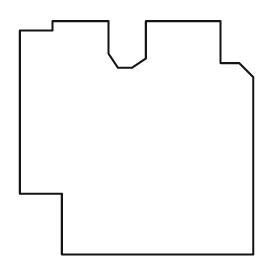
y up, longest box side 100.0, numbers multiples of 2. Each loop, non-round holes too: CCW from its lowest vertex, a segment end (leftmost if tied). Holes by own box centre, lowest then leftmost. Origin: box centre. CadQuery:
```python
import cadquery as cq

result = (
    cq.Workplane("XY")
    .moveTo(-32.0, -50.0)
    .lineTo(50.0, -50.0)
    .lineTo(50.0, 26.0)
    .lineTo(44.0, 32.0)
    .lineTo(36.0, 32.0)
    .lineTo(36.0, 50.0)
    .lineTo(4.0, 50.0)
    .lineTo(4.0, 34.0)
    .lineTo(-2.0, 30.0)
    .lineTo(-8.0, 30.0)
    .lineTo(-12.0, 36.0)
    .lineTo(-12.0, 50.0)
    .lineTo(-36.0, 50.0)
    .lineTo(-36.0, 46.0)
    .lineTo(-50.0, 46.0)
    .lineTo(-50.0, -24.0)
    .lineTo(-32.0, -24.0)
    .close()
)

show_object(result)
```